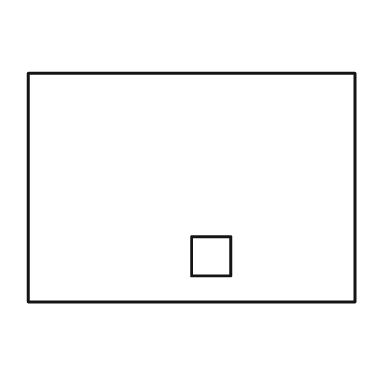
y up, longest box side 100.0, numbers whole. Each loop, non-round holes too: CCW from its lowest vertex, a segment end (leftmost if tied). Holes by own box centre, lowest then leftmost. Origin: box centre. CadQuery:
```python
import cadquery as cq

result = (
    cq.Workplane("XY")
    .moveTo(-50.0, -35.0)
    .lineTo(50.0, -35.0)
    .lineTo(50.0, 35.0)
    .lineTo(-50.0, 35.0)
    .close()
    .moveTo(0.0, -27.0)
    .lineTo(12.0, -27.0)
    .lineTo(12.0, -15.0)
    .lineTo(0.0, -15.0)
    .close()
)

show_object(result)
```